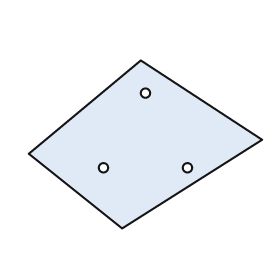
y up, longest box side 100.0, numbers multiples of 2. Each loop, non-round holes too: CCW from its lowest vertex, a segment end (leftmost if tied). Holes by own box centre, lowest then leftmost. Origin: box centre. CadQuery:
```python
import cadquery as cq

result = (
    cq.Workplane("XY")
    .moveTo(-10.0, -36.0)
    .lineTo(50.0, 2.0)
    .lineTo(-2.0, 36.0)
    .lineTo(-50.0, -4.0)
    .close()
    .moveTo(-18.0, -10.0)
    .circle(2.0)
    .moveTo(18.0, -10.0)
    .circle(2.0)
    .moveTo(0.0, 22.0)
    .circle(2.0)
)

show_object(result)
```